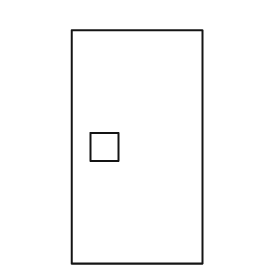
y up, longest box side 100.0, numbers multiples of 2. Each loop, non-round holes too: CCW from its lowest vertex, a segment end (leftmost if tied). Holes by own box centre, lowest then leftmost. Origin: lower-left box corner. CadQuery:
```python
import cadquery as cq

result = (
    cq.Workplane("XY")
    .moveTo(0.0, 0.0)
    .lineTo(56.0, 0.0)
    .lineTo(56.0, 100.0)
    .lineTo(0.0, 100.0)
    .close()
    .moveTo(8.0, 44.0)
    .lineTo(20.0, 44.0)
    .lineTo(20.0, 56.0)
    .lineTo(8.0, 56.0)
    .close()
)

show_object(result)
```